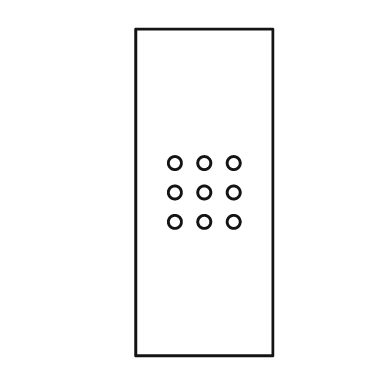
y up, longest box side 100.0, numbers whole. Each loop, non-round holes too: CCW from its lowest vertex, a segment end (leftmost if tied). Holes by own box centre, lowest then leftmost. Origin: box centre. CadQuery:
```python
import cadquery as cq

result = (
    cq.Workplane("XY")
    .moveTo(-21.0, -50.0)
    .lineTo(21.0, -50.0)
    .lineTo(21.0, 50.0)
    .lineTo(-21.0, 50.0)
    .close()
    .moveTo(-9.0, -9.0)
    .circle(2.0)
    .moveTo(0.0, -9.0)
    .circle(2.0)
    .moveTo(9.0, -9.0)
    .circle(2.0)
    .moveTo(-9.0, 0.0)
    .circle(2.0)
    .moveTo(0.0, 0.0)
    .circle(2.0)
    .moveTo(9.0, 0.0)
    .circle(2.0)
    .moveTo(-9.0, 9.0)
    .circle(2.0)
    .moveTo(0.0, 9.0)
    .circle(2.0)
    .moveTo(9.0, 9.0)
    .circle(2.0)
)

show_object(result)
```